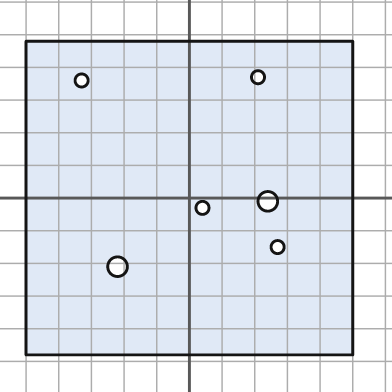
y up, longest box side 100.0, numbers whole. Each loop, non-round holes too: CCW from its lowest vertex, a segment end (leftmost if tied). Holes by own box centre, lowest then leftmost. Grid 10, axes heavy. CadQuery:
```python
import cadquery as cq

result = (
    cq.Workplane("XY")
    .moveTo(-50.0, -48.0)
    .lineTo(50.0, -48.0)
    .lineTo(50.0, 48.0)
    .lineTo(-50.0, 48.0)
    .close()
    .moveTo(-22.0, -21.0)
    .circle(3.0)
    .moveTo(27.0, -15.0)
    .circle(2.0)
    .moveTo(4.0, -3.0)
    .circle(2.0)
    .moveTo(24.0, -1.0)
    .circle(3.0)
    .moveTo(-33.0, 36.0)
    .circle(2.0)
    .moveTo(21.0, 37.0)
    .circle(2.0)
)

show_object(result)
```